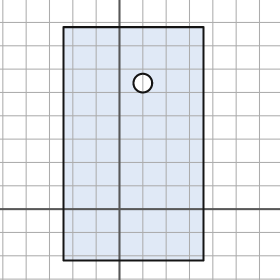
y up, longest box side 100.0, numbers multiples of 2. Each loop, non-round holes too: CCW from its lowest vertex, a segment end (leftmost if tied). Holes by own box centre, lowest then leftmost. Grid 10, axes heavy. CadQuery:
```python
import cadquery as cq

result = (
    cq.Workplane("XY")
    .moveTo(-24.0, -22.0)
    .lineTo(36.0, -22.0)
    .lineTo(36.0, 78.0)
    .lineTo(-24.0, 78.0)
    .close()
    .moveTo(10.0, 54.0)
    .circle(4.0)
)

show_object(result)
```